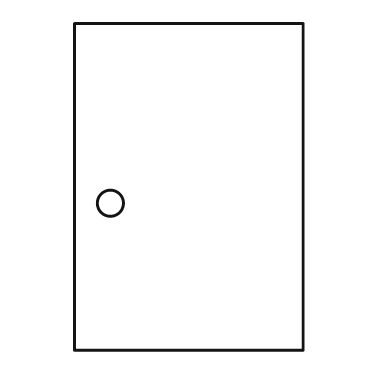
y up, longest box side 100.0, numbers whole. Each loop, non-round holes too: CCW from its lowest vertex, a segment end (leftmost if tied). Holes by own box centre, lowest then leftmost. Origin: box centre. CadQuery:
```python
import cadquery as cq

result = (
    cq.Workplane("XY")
    .moveTo(-35.0, -50.0)
    .lineTo(35.0, -50.0)
    .lineTo(35.0, 50.0)
    .lineTo(-35.0, 50.0)
    .close()
    .moveTo(-24.0, -5.0)
    .circle(4.0)
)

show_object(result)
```